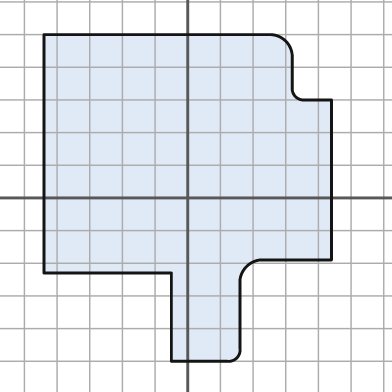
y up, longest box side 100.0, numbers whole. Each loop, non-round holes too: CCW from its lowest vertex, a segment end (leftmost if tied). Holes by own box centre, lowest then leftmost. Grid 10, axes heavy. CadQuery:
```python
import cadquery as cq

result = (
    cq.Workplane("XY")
    .moveTo(-5.0, -50.0)
    .lineTo(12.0, -50.0)
    .threePointArc((15.0, -49.0), (16.0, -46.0))
    .lineTo(16.0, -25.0)
    .threePointArc((18.0, -21.0), (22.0, -19.0))
    .lineTo(44.0, -19.0)
    .lineTo(44.0, 30.0)
    .lineTo(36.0, 30.0)
    .threePointArc((33.0, 31.0), (32.0, 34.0))
    .lineTo(32.0, 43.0)
    .threePointArc((30.0, 48.0), (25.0, 50.0))
    .lineTo(-44.0, 50.0)
    .lineTo(-44.0, -23.0)
    .lineTo(-5.0, -23.0)
    .close()
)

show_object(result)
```